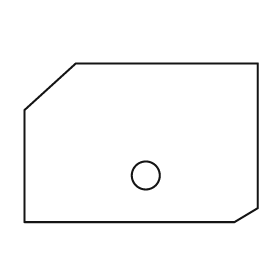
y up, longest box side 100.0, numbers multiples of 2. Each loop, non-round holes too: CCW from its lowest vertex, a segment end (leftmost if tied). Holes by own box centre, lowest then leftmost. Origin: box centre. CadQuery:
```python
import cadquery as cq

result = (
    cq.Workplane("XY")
    .moveTo(-50.0, -34.0)
    .lineTo(40.0, -34.0)
    .lineTo(50.0, -28.0)
    .lineTo(50.0, 34.0)
    .lineTo(-28.0, 34.0)
    .lineTo(-50.0, 14.0)
    .close()
    .moveTo(2.0, -14.0)
    .circle(6.0)
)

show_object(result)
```